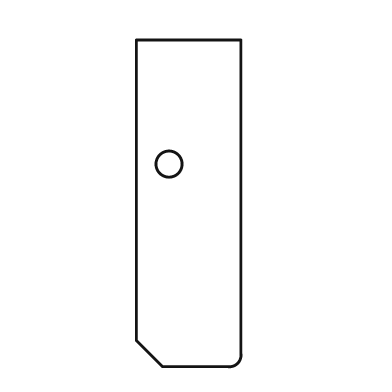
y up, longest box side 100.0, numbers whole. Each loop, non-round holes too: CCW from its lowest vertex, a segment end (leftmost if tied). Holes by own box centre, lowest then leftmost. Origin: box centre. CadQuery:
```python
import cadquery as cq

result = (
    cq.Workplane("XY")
    .moveTo(-8.0, -50.0)
    .lineTo(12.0, -50.0)
    .threePointArc((15.0, -49.0), (16.0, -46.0))
    .lineTo(16.0, 50.0)
    .lineTo(-16.0, 50.0)
    .lineTo(-16.0, -42.0)
    .close()
    .moveTo(-6.0, 12.0)
    .circle(4.0)
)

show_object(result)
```